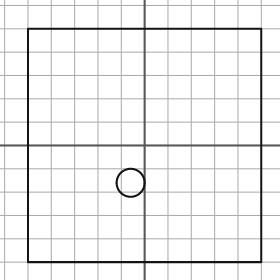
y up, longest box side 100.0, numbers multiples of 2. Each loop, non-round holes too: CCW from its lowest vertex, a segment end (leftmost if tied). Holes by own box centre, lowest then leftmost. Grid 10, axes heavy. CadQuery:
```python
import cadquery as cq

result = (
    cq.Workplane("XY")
    .moveTo(-50.0, -50.0)
    .lineTo(50.0, -50.0)
    .lineTo(50.0, 50.0)
    .lineTo(-50.0, 50.0)
    .close()
    .moveTo(-6.0, -16.0)
    .circle(6.0)
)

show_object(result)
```